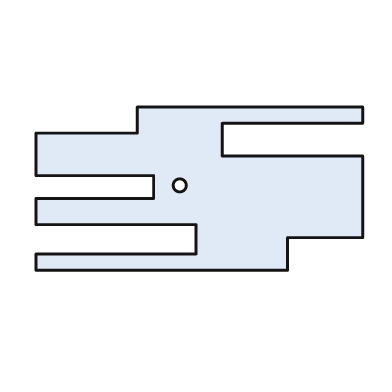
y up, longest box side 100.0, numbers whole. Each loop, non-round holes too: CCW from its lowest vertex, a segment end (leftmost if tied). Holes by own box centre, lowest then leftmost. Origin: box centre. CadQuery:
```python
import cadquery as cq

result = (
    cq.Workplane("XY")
    .moveTo(-50.0, -25.0)
    .lineTo(27.0, -25.0)
    .lineTo(27.0, -15.0)
    .lineTo(50.0, -15.0)
    .lineTo(50.0, 10.0)
    .lineTo(7.0, 10.0)
    .lineTo(7.0, 20.0)
    .lineTo(50.0, 20.0)
    .lineTo(50.0, 25.0)
    .lineTo(-19.0, 25.0)
    .lineTo(-19.0, 17.0)
    .lineTo(-50.0, 17.0)
    .lineTo(-50.0, 4.0)
    .lineTo(-14.0, 4.0)
    .lineTo(-14.0, -3.0)
    .lineTo(-50.0, -3.0)
    .lineTo(-50.0, -11.0)
    .lineTo(-1.0, -11.0)
    .lineTo(-1.0, -20.0)
    .lineTo(-50.0, -20.0)
    .close()
    .moveTo(-6.0, 1.0)
    .circle(2.0)
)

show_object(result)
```